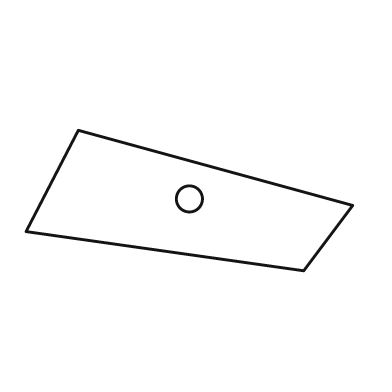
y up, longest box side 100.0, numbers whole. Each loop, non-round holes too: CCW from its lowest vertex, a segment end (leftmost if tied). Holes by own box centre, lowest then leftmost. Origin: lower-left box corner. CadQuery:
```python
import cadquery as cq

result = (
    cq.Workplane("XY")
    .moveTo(85.0, 0.0)
    .lineTo(100.0, 20.0)
    .lineTo(16.0, 43.0)
    .lineTo(0.0, 12.0)
    .close()
    .moveTo(50.0, 22.0)
    .circle(4.0)
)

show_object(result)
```